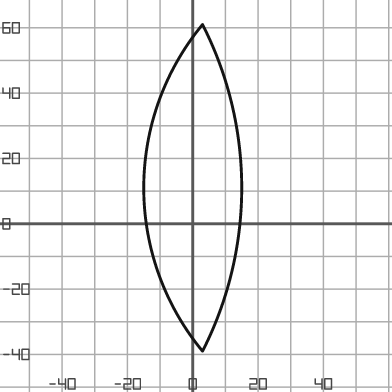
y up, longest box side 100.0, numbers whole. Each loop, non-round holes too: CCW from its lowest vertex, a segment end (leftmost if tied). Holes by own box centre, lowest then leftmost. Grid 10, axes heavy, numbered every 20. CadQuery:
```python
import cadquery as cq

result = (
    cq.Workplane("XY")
    .moveTo(3.0, -39.0)
    .threePointArc((15.0, 11.0), (3.0, 61.0))
    .threePointArc((-15.0, 11.0), (3.0, -39.0))
    .close()
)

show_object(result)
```